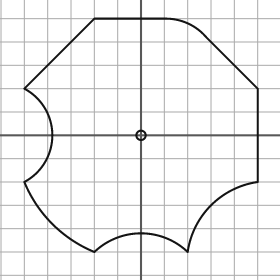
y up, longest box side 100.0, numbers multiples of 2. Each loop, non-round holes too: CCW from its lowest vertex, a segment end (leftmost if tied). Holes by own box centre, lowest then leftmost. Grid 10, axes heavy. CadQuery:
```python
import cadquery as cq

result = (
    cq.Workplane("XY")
    .moveTo(-20.0, -50.0)
    .threePointArc((0.0, -42.0), (20.0, -50.0))
    .threePointArc((30.0, -30.0), (50.0, -20.0))
    .lineTo(50.0, 20.0)
    .lineTo(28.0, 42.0)
    .threePointArc((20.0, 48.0), (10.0, 50.0))
    .lineTo(-20.0, 50.0)
    .lineTo(-50.0, 20.0)
    .threePointArc((-38.0, 0.0), (-50.0, -20.0))
    .threePointArc((-38.0, -38.0), (-20.0, -50.0))
    .close()
    .moveTo(0.0, 0.0)
    .circle(2.0)
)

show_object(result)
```